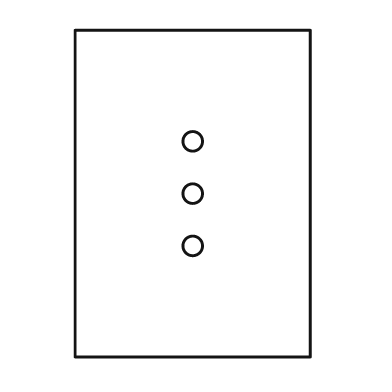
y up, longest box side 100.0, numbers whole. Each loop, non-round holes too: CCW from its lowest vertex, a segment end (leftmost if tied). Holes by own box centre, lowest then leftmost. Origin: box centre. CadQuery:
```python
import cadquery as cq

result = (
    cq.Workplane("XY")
    .moveTo(-36.0, -50.0)
    .lineTo(36.0, -50.0)
    .lineTo(36.0, 50.0)
    .lineTo(-36.0, 50.0)
    .close()
    .moveTo(0.0, -16.0)
    .circle(3.0)
    .moveTo(0.0, 0.0)
    .circle(3.0)
    .moveTo(0.0, 16.0)
    .circle(3.0)
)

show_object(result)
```